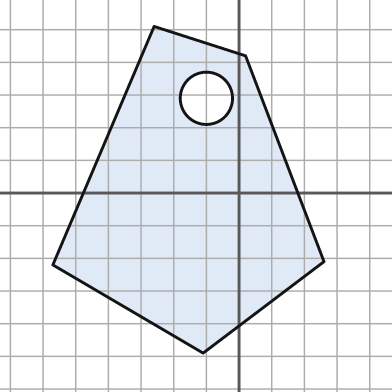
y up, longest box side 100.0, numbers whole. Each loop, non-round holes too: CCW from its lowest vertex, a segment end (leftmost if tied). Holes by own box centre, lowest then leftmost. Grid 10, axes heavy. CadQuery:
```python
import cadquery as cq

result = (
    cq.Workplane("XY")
    .moveTo(-11.0, -49.0)
    .lineTo(26.0, -21.0)
    .lineTo(2.0, 42.0)
    .lineTo(-26.0, 51.0)
    .lineTo(-57.0, -22.0)
    .close()
    .moveTo(-10.0, 29.0)
    .circle(8.0)
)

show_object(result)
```